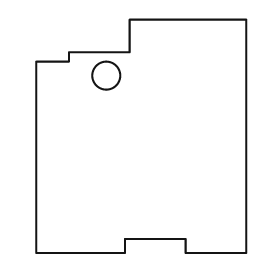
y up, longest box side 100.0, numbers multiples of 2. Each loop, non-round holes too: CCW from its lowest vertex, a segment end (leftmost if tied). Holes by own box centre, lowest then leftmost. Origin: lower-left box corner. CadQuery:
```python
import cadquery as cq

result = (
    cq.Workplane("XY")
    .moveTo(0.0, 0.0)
    .lineTo(38.0, 0.0)
    .lineTo(38.0, 6.0)
    .lineTo(64.0, 6.0)
    .lineTo(64.0, 0.0)
    .lineTo(90.0, 0.0)
    .lineTo(90.0, 100.0)
    .lineTo(40.0, 100.0)
    .lineTo(40.0, 86.0)
    .lineTo(14.0, 86.0)
    .lineTo(14.0, 82.0)
    .lineTo(0.0, 82.0)
    .close()
    .moveTo(30.0, 76.0)
    .circle(6.0)
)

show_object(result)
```